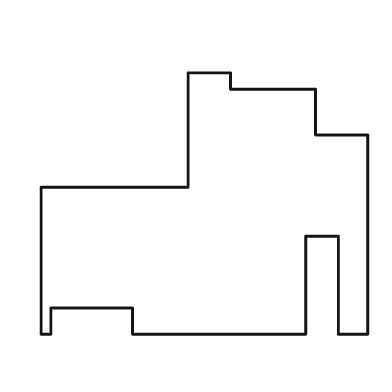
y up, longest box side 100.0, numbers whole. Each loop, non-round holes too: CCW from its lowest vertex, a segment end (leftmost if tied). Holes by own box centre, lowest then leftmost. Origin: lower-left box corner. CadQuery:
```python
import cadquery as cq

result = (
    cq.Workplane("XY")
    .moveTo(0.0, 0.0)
    .lineTo(3.0, 0.0)
    .lineTo(3.0, 8.0)
    .lineTo(28.0, 8.0)
    .lineTo(28.0, 0.0)
    .lineTo(81.0, 0.0)
    .lineTo(81.0, 30.0)
    .lineTo(91.0, 30.0)
    .lineTo(91.0, 0.0)
    .lineTo(100.0, 0.0)
    .lineTo(100.0, 61.0)
    .lineTo(84.0, 61.0)
    .lineTo(84.0, 75.0)
    .lineTo(58.0, 75.0)
    .lineTo(58.0, 80.0)
    .lineTo(45.0, 80.0)
    .lineTo(45.0, 45.0)
    .lineTo(0.0, 45.0)
    .close()
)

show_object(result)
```